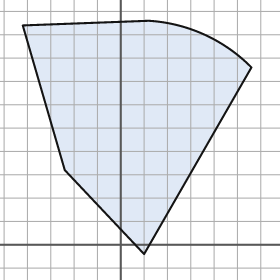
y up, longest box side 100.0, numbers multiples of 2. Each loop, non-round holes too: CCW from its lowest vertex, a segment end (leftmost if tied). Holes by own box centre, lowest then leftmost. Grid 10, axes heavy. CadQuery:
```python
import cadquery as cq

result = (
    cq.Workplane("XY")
    .moveTo(10.0, -4.0)
    .lineTo(56.0, 76.0)
    .threePointArc((36.0, 90.0), (12.0, 96.0))
    .lineTo(-42.0, 94.0)
    .lineTo(-24.0, 32.0)
    .close()
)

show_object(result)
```